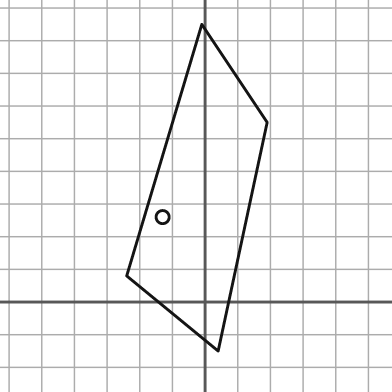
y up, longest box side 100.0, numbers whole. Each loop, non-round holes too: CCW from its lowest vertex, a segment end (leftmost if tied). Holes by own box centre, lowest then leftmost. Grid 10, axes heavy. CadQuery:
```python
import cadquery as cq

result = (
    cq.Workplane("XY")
    .moveTo(4.0, -15.0)
    .lineTo(19.0, 55.0)
    .lineTo(-1.0, 85.0)
    .lineTo(-24.0, 8.0)
    .close()
    .moveTo(-13.0, 26.0)
    .circle(2.0)
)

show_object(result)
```